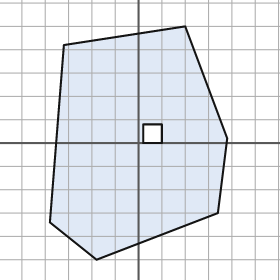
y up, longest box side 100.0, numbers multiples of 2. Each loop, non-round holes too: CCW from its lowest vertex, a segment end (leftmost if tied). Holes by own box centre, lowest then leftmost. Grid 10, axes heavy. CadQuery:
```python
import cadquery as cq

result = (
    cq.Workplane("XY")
    .moveTo(-18.0, -50.0)
    .lineTo(34.0, -30.0)
    .lineTo(38.0, 2.0)
    .lineTo(20.0, 50.0)
    .lineTo(-32.0, 42.0)
    .lineTo(-38.0, -34.0)
    .close()
    .moveTo(2.0, 0.0)
    .lineTo(10.0, 0.0)
    .lineTo(10.0, 8.0)
    .lineTo(2.0, 8.0)
    .close()
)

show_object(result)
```